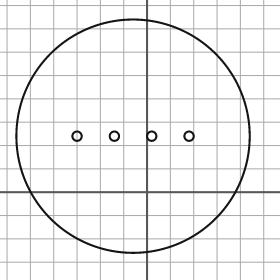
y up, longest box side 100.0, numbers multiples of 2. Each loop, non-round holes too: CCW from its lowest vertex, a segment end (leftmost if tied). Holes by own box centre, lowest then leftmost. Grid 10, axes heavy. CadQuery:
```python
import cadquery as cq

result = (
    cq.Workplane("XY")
    .moveTo(-6.0, 24.0)
    .circle(50.0)
    .moveTo(-30.0, 24.0)
    .circle(2.0)
    .moveTo(-14.0, 24.0)
    .circle(2.0)
    .moveTo(2.0, 24.0)
    .circle(2.0)
    .moveTo(18.0, 24.0)
    .circle(2.0)
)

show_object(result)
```